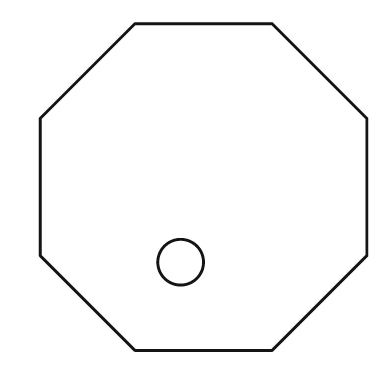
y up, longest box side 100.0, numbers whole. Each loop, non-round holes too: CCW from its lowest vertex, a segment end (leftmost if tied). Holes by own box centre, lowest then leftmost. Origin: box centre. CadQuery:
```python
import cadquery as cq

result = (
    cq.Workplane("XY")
    .moveTo(-21.0, -50.0)
    .lineTo(21.0, -50.0)
    .lineTo(50.0, -21.0)
    .lineTo(50.0, 21.0)
    .lineTo(21.0, 50.0)
    .lineTo(-21.0, 50.0)
    .lineTo(-50.0, 21.0)
    .lineTo(-50.0, -21.0)
    .close()
    .moveTo(-7.0, -23.0)
    .circle(7.0)
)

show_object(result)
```